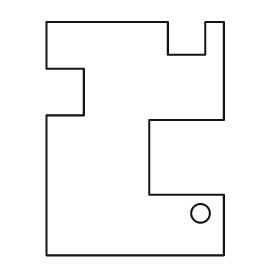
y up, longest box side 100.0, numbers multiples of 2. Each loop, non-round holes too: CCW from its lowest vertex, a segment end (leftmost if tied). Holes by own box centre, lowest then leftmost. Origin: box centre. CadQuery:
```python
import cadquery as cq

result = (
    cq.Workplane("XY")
    .moveTo(-38.0, -50.0)
    .lineTo(38.0, -50.0)
    .lineTo(38.0, -24.0)
    .lineTo(6.0, -24.0)
    .lineTo(6.0, 8.0)
    .lineTo(38.0, 8.0)
    .lineTo(38.0, 50.0)
    .lineTo(30.0, 50.0)
    .lineTo(30.0, 36.0)
    .lineTo(14.0, 36.0)
    .lineTo(14.0, 50.0)
    .lineTo(-38.0, 50.0)
    .lineTo(-38.0, 30.0)
    .lineTo(-22.0, 30.0)
    .lineTo(-22.0, 10.0)
    .lineTo(-38.0, 10.0)
    .close()
    .moveTo(28.0, -32.0)
    .circle(4.0)
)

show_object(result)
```